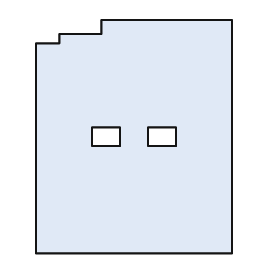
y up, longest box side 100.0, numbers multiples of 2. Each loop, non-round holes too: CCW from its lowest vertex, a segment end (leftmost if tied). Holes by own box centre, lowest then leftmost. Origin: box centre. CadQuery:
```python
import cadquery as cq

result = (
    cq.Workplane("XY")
    .moveTo(-42.0, -50.0)
    .lineTo(42.0, -50.0)
    .lineTo(42.0, 50.0)
    .lineTo(-14.0, 50.0)
    .lineTo(-14.0, 44.0)
    .lineTo(-32.0, 44.0)
    .lineTo(-32.0, 40.0)
    .lineTo(-42.0, 40.0)
    .close()
    .moveTo(-18.0, -4.0)
    .lineTo(-6.0, -4.0)
    .lineTo(-6.0, 4.0)
    .lineTo(-18.0, 4.0)
    .close()
    .moveTo(6.0, -4.0)
    .lineTo(18.0, -4.0)
    .lineTo(18.0, 4.0)
    .lineTo(6.0, 4.0)
    .close()
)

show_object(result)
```